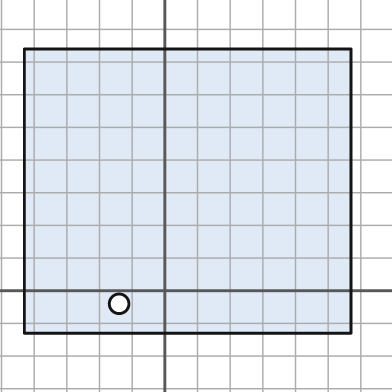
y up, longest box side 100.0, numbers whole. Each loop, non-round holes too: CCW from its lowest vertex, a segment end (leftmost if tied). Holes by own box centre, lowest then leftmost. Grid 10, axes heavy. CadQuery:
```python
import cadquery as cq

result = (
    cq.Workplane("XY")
    .moveTo(-43.0, -13.0)
    .lineTo(57.0, -13.0)
    .lineTo(57.0, 74.0)
    .lineTo(-43.0, 74.0)
    .close()
    .moveTo(-14.0, -4.0)
    .circle(3.0)
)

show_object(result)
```